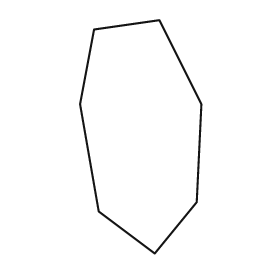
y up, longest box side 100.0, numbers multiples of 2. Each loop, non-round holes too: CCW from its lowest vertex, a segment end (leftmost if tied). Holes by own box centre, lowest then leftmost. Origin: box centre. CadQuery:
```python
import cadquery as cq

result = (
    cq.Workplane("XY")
    .moveTo(6.0, -50.0)
    .lineTo(24.0, -28.0)
    .lineTo(26.0, 14.0)
    .lineTo(8.0, 50.0)
    .lineTo(-20.0, 46.0)
    .lineTo(-26.0, 14.0)
    .lineTo(-18.0, -32.0)
    .close()
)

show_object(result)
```